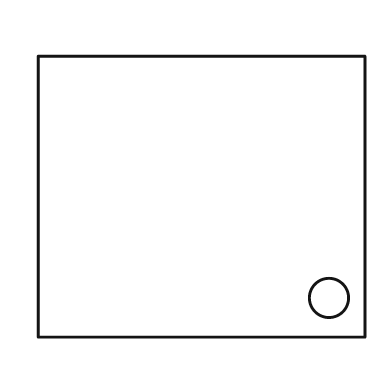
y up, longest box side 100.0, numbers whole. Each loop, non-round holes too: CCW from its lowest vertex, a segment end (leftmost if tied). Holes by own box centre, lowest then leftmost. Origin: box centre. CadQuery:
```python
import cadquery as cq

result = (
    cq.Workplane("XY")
    .moveTo(-50.0, -43.0)
    .lineTo(50.0, -43.0)
    .lineTo(50.0, 43.0)
    .lineTo(-50.0, 43.0)
    .close()
    .moveTo(39.0, -31.0)
    .circle(6.0)
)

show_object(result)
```